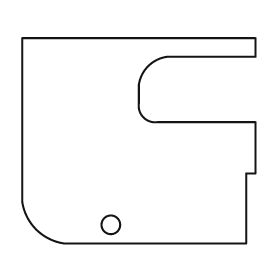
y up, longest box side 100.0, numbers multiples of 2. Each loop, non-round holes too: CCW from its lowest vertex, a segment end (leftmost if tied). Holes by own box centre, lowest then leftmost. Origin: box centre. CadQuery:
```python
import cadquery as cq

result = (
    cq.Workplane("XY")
    .moveTo(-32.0, -44.0)
    .lineTo(46.0, -44.0)
    .lineTo(46.0, -14.0)
    .lineTo(50.0, -14.0)
    .lineTo(50.0, 8.0)
    .lineTo(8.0, 8.0)
    .threePointArc((2.0, 10.0), (0.0, 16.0))
    .lineTo(0.0, 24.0)
    .threePointArc((4.0, 32.0), (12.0, 36.0))
    .lineTo(50.0, 36.0)
    .lineTo(50.0, 44.0)
    .lineTo(-50.0, 44.0)
    .lineTo(-50.0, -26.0)
    .threePointArc((-44.0, -38.0), (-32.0, -44.0))
    .close()
    .moveTo(-12.0, -36.0)
    .circle(4.0)
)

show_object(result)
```